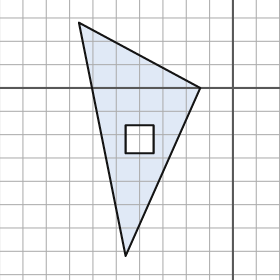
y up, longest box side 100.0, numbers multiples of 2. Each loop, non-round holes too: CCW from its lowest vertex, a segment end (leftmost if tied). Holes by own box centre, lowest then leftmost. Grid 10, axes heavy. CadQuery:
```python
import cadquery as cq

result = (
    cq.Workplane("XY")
    .moveTo(-46.0, -72.0)
    .lineTo(-14.0, 0.0)
    .lineTo(-66.0, 28.0)
    .close()
    .moveTo(-46.0, -28.0)
    .lineTo(-34.0, -28.0)
    .lineTo(-34.0, -16.0)
    .lineTo(-46.0, -16.0)
    .close()
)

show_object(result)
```